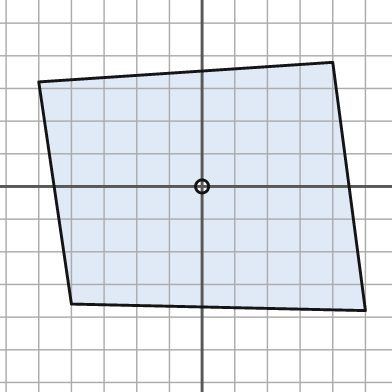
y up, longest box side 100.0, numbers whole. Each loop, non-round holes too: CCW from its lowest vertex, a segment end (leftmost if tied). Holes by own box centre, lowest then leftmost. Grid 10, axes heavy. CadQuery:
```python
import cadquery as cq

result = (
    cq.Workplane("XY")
    .moveTo(50.0, -38.0)
    .lineTo(40.0, 38.0)
    .lineTo(-50.0, 32.0)
    .lineTo(-40.0, -36.0)
    .close()
    .moveTo(0.0, 0.0)
    .circle(2.0)
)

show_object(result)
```